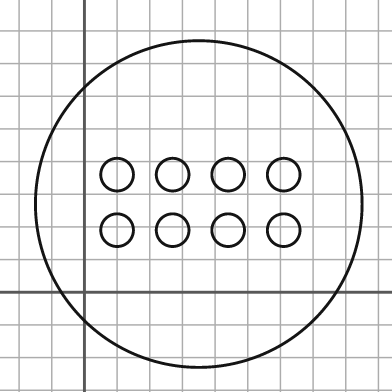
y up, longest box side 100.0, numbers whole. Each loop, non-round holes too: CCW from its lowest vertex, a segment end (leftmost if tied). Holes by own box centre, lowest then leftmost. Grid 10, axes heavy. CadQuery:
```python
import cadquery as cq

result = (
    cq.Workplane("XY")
    .moveTo(35.0, 27.0)
    .circle(50.0)
    .moveTo(10.0, 19.0)
    .circle(5.0)
    .moveTo(27.0, 19.0)
    .circle(5.0)
    .moveTo(44.0, 19.0)
    .circle(5.0)
    .moveTo(61.0, 19.0)
    .circle(5.0)
    .moveTo(10.0, 36.0)
    .circle(5.0)
    .moveTo(27.0, 36.0)
    .circle(5.0)
    .moveTo(44.0, 36.0)
    .circle(5.0)
    .moveTo(61.0, 36.0)
    .circle(5.0)
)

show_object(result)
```